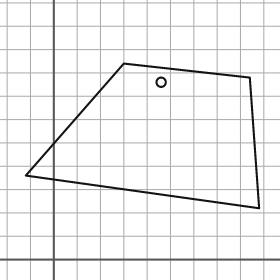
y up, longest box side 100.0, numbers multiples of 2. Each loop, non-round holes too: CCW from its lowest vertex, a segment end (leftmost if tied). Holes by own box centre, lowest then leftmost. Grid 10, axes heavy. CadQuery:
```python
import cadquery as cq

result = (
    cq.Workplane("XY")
    .moveTo(88.0, 22.0)
    .lineTo(84.0, 78.0)
    .lineTo(30.0, 84.0)
    .lineTo(-12.0, 36.0)
    .close()
    .moveTo(46.0, 76.0)
    .circle(2.0)
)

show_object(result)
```